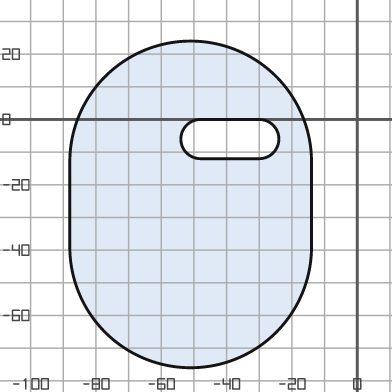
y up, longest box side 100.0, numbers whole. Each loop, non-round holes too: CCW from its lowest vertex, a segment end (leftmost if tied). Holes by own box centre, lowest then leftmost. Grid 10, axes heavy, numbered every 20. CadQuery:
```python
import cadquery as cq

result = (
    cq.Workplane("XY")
    .moveTo(-88.0, -39.0)
    .threePointArc((-51.0, -76.0), (-14.0, -39.0))
    .lineTo(-14.0, -13.0)
    .threePointArc((-51.0, 24.0), (-88.0, -13.0))
    .close()
    .moveTo(-48.0, -12.0)
    .lineTo(-30.0, -12.0)
    .threePointArc((-24.0, -6.0), (-30.0, 0.0))
    .lineTo(-48.0, 0.0)
    .threePointArc((-54.0, -6.0), (-48.0, -12.0))
    .close()
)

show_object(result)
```